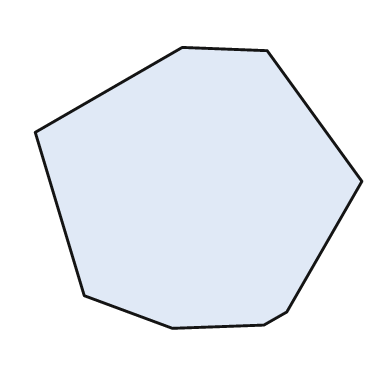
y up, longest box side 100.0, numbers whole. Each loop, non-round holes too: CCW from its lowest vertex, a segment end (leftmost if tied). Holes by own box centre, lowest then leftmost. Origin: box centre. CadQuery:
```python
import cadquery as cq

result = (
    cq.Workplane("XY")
    .moveTo(-8.0, -43.0)
    .lineTo(20.0, -42.0)
    .lineTo(27.0, -38.0)
    .lineTo(50.0, 2.0)
    .lineTo(21.0, 42.0)
    .lineTo(-5.0, 43.0)
    .lineTo(-50.0, 17.0)
    .lineTo(-35.0, -33.0)
    .close()
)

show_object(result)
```